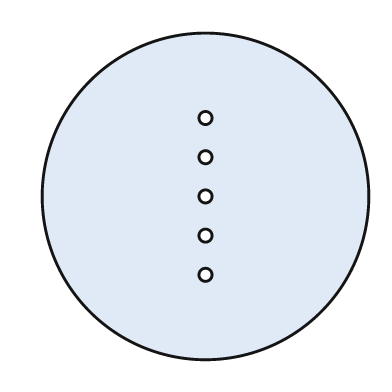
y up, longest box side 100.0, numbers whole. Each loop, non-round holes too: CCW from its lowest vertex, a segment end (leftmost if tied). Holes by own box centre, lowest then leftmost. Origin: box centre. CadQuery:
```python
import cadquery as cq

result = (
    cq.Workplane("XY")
    .moveTo(0.0, 0.0)
    .circle(50.0)
    .moveTo(0.0, -24.0)
    .circle(2.0)
    .moveTo(0.0, -12.0)
    .circle(2.0)
    .moveTo(0.0, 0.0)
    .circle(2.0)
    .moveTo(0.0, 12.0)
    .circle(2.0)
    .moveTo(0.0, 24.0)
    .circle(2.0)
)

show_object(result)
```